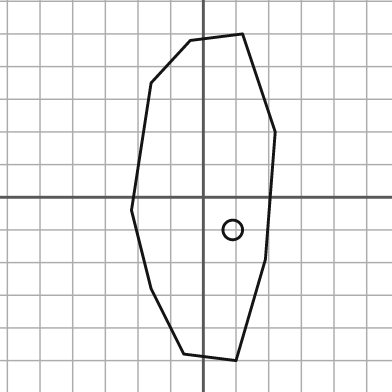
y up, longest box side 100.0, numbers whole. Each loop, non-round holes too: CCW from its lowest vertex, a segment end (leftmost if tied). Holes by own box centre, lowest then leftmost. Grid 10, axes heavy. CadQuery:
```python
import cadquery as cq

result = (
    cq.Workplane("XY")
    .moveTo(10.0, -50.0)
    .lineTo(19.0, -19.0)
    .lineTo(22.0, 20.0)
    .lineTo(12.0, 50.0)
    .lineTo(-4.0, 48.0)
    .lineTo(-16.0, 35.0)
    .lineTo(-22.0, -4.0)
    .lineTo(-16.0, -28.0)
    .lineTo(-6.0, -48.0)
    .close()
    .moveTo(9.0, -10.0)
    .circle(3.0)
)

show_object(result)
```